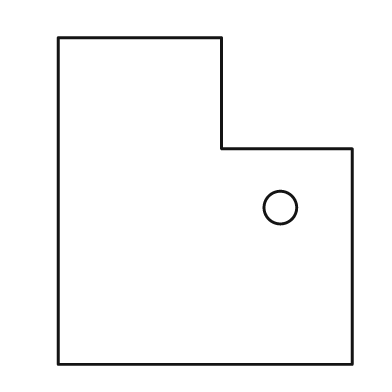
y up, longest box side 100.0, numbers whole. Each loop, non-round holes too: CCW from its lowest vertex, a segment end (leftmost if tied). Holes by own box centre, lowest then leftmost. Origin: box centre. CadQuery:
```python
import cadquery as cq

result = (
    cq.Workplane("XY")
    .moveTo(-45.0, -50.0)
    .lineTo(45.0, -50.0)
    .lineTo(45.0, 16.0)
    .lineTo(5.0, 16.0)
    .lineTo(5.0, 50.0)
    .lineTo(-45.0, 50.0)
    .close()
    .moveTo(23.0, -2.0)
    .circle(5.0)
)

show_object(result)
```